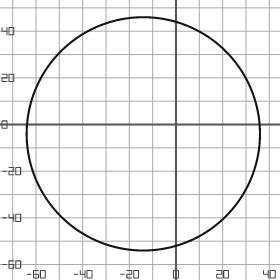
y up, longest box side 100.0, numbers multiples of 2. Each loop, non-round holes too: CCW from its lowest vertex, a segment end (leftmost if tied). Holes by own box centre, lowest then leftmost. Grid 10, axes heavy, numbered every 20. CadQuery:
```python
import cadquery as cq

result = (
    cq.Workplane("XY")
    .moveTo(-14.0, -4.0)
    .circle(50.0)
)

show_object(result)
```